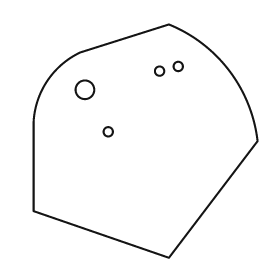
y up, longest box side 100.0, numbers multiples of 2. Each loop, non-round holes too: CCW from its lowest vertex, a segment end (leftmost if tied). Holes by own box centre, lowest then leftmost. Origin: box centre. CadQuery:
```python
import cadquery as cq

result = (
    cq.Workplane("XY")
    .moveTo(10.0, -50.0)
    .lineTo(48.0, 0.0)
    .threePointArc((36.0, 30.0), (10.0, 50.0))
    .lineTo(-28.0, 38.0)
    .threePointArc((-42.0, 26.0), (-48.0, 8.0))
    .lineTo(-48.0, -30.0)
    .close()
    .moveTo(-16.0, 4.0)
    .circle(2.0)
    .moveTo(-26.0, 22.0)
    .circle(4.0)
    .moveTo(6.0, 30.0)
    .circle(2.0)
    .moveTo(14.0, 32.0)
    .circle(2.0)
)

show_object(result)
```